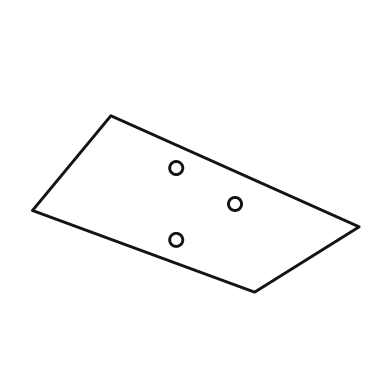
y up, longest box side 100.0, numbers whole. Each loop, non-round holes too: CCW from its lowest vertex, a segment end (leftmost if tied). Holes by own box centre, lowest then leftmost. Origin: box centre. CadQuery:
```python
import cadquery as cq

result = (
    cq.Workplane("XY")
    .moveTo(18.0, -27.0)
    .lineTo(50.0, -7.0)
    .lineTo(-26.0, 27.0)
    .lineTo(-50.0, -2.0)
    .close()
    .moveTo(-6.0, -11.0)
    .circle(2.0)
    .moveTo(12.0, 0.0)
    .circle(2.0)
    .moveTo(-6.0, 11.0)
    .circle(2.0)
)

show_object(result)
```